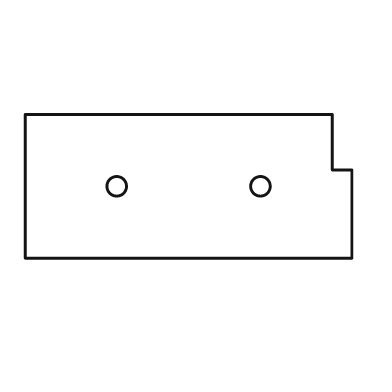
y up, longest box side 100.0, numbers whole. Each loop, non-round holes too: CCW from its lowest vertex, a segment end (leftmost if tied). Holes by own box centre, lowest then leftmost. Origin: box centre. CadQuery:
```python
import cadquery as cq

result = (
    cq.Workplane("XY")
    .moveTo(-50.0, -22.0)
    .lineTo(50.0, -22.0)
    .lineTo(50.0, 5.0)
    .lineTo(44.0, 5.0)
    .lineTo(44.0, 22.0)
    .lineTo(-50.0, 22.0)
    .close()
    .moveTo(-22.0, 0.0)
    .circle(3.0)
    .moveTo(22.0, 0.0)
    .circle(3.0)
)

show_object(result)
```